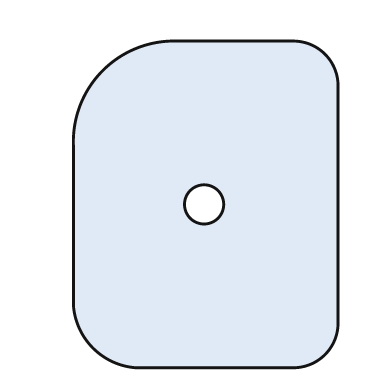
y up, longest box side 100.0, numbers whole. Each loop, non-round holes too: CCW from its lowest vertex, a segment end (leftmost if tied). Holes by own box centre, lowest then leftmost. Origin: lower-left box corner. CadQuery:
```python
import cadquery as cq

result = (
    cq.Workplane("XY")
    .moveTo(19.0, 0.0)
    .lineTo(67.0, 0.0)
    .threePointArc((77.0, 4.0), (81.0, 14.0))
    .lineTo(81.0, 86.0)
    .threePointArc((77.0, 96.0), (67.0, 100.0))
    .lineTo(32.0, 100.0)
    .threePointArc((9.0, 91.0), (0.0, 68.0))
    .lineTo(0.0, 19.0)
    .threePointArc((6.0, 6.0), (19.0, 0.0))
    .close()
    .moveTo(40.0, 50.0)
    .circle(6.0)
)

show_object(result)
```